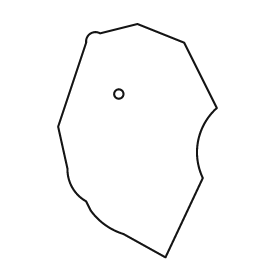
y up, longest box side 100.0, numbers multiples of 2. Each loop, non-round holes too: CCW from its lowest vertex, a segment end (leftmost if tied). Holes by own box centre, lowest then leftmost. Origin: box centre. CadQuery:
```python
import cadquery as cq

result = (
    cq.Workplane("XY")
    .moveTo(12.0, -50.0)
    .lineTo(28.0, -16.0)
    .threePointArc((26.0, 0.0), (34.0, 14.0))
    .lineTo(20.0, 42.0)
    .lineTo(0.0, 50.0)
    .lineTo(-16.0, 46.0)
    .threePointArc((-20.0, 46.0), (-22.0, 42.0))
    .lineTo(-34.0, 6.0)
    .lineTo(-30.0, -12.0)
    .threePointArc((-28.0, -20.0), (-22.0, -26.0))
    .lineTo(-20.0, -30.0)
    .threePointArc((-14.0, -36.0), (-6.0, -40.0))
    .close()
    .moveTo(-8.0, 20.0)
    .circle(2.0)
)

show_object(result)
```